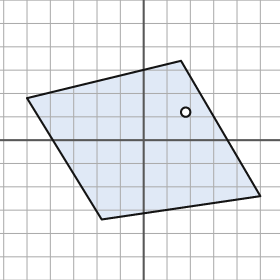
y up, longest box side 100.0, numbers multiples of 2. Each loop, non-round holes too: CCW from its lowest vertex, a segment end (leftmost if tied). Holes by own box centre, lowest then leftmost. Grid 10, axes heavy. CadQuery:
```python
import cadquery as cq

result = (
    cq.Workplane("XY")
    .moveTo(-18.0, -34.0)
    .lineTo(50.0, -24.0)
    .lineTo(16.0, 34.0)
    .lineTo(-50.0, 18.0)
    .close()
    .moveTo(18.0, 12.0)
    .circle(2.0)
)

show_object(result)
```